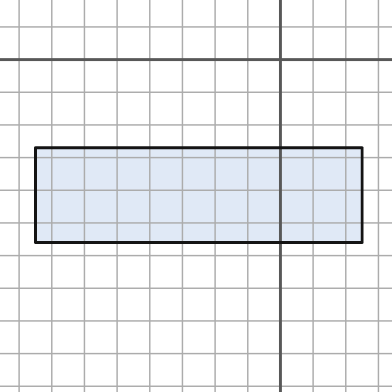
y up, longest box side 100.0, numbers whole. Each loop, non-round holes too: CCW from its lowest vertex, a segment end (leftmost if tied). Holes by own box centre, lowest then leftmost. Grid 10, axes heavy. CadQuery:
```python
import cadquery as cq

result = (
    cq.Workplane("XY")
    .moveTo(-75.0, -56.0)
    .lineTo(25.0, -56.0)
    .lineTo(25.0, -27.0)
    .lineTo(-75.0, -27.0)
    .close()
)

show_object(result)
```